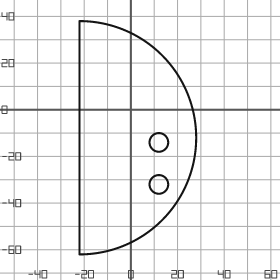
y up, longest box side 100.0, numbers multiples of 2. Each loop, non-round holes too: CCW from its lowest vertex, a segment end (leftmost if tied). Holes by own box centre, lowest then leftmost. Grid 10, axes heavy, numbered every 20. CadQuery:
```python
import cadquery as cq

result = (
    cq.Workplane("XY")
    .moveTo(-22.0, -62.0)
    .threePointArc((28.0, -12.0), (-22.0, 38.0))
    .close()
    .moveTo(12.0, -32.0)
    .circle(4.0)
    .moveTo(12.0, -14.0)
    .circle(4.0)
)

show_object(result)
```